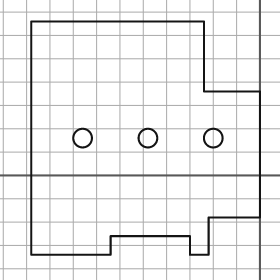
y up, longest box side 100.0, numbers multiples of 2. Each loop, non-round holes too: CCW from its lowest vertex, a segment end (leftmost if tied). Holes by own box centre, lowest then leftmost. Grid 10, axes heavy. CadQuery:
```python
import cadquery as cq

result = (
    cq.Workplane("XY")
    .moveTo(-98.0, -34.0)
    .lineTo(-64.0, -34.0)
    .lineTo(-64.0, -26.0)
    .lineTo(-30.0, -26.0)
    .lineTo(-30.0, -34.0)
    .lineTo(-22.0, -34.0)
    .lineTo(-22.0, -18.0)
    .lineTo(0.0, -18.0)
    .lineTo(0.0, 36.0)
    .lineTo(-24.0, 36.0)
    .lineTo(-24.0, 66.0)
    .lineTo(-98.0, 66.0)
    .close()
    .moveTo(-76.0, 16.0)
    .circle(4.0)
    .moveTo(-48.0, 16.0)
    .circle(4.0)
    .moveTo(-20.0, 16.0)
    .circle(4.0)
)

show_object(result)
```